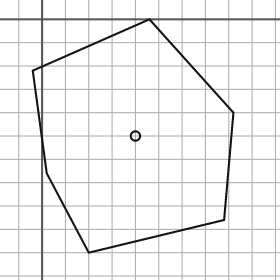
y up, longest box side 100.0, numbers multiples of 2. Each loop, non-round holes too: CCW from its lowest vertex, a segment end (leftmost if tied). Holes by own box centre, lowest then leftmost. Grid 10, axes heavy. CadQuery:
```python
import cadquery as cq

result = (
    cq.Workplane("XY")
    .moveTo(20.0, -100.0)
    .lineTo(78.0, -86.0)
    .lineTo(82.0, -40.0)
    .lineTo(46.0, 0.0)
    .lineTo(-4.0, -22.0)
    .lineTo(2.0, -66.0)
    .close()
    .moveTo(40.0, -50.0)
    .circle(2.0)
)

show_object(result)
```